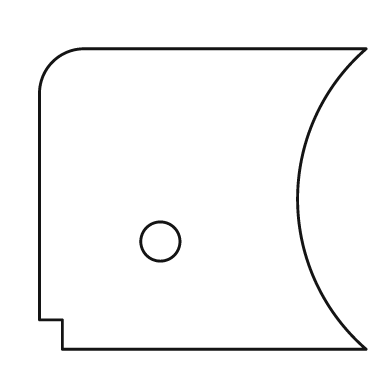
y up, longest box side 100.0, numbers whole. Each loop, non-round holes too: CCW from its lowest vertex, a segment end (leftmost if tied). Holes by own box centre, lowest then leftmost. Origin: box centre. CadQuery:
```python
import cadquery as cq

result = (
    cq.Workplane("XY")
    .moveTo(-43.0, -46.0)
    .lineTo(50.0, -46.0)
    .threePointArc((29.0, 0.0), (50.0, 46.0))
    .lineTo(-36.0, 46.0)
    .threePointArc((-46.0, 42.0), (-50.0, 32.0))
    .lineTo(-50.0, -37.0)
    .lineTo(-43.0, -37.0)
    .close()
    .moveTo(-13.0, -13.0)
    .circle(6.0)
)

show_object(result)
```